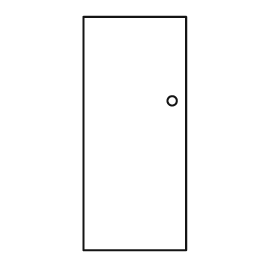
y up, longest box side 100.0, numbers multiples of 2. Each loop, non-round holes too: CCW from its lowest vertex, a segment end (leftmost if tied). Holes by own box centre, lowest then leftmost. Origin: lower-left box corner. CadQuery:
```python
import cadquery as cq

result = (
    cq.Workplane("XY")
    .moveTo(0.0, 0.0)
    .lineTo(44.0, 0.0)
    .lineTo(44.0, 100.0)
    .lineTo(0.0, 100.0)
    .close()
    .moveTo(38.0, 64.0)
    .circle(2.0)
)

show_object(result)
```